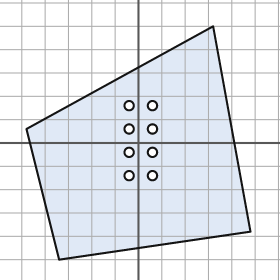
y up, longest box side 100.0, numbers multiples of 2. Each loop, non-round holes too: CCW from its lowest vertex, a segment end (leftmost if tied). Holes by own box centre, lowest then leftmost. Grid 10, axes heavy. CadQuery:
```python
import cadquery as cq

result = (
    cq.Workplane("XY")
    .moveTo(-34.0, -50.0)
    .lineTo(48.0, -38.0)
    .lineTo(32.0, 50.0)
    .lineTo(-48.0, 6.0)
    .close()
    .moveTo(-4.0, -14.0)
    .circle(2.0)
    .moveTo(6.0, -14.0)
    .circle(2.0)
    .moveTo(-4.0, -4.0)
    .circle(2.0)
    .moveTo(6.0, -4.0)
    .circle(2.0)
    .moveTo(-4.0, 6.0)
    .circle(2.0)
    .moveTo(6.0, 6.0)
    .circle(2.0)
    .moveTo(-4.0, 16.0)
    .circle(2.0)
    .moveTo(6.0, 16.0)
    .circle(2.0)
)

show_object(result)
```